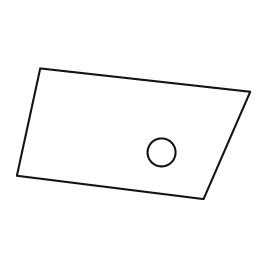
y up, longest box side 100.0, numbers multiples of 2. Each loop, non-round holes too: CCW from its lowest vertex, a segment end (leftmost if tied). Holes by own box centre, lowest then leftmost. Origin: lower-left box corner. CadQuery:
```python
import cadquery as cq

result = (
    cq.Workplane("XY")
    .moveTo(80.0, 0.0)
    .lineTo(100.0, 46.0)
    .lineTo(10.0, 56.0)
    .lineTo(0.0, 10.0)
    .close()
    .moveTo(62.0, 20.0)
    .circle(6.0)
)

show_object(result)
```